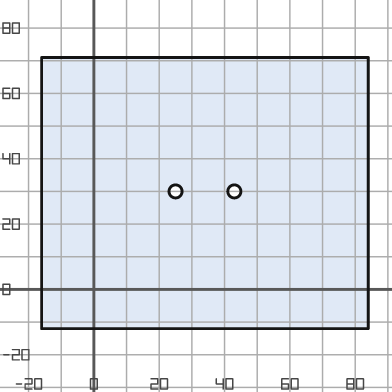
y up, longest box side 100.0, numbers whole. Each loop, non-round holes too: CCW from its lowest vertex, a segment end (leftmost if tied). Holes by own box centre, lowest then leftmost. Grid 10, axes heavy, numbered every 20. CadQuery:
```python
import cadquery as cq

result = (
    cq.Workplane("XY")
    .moveTo(-16.0, -12.0)
    .lineTo(84.0, -12.0)
    .lineTo(84.0, 71.0)
    .lineTo(-16.0, 71.0)
    .close()
    .moveTo(25.0, 30.0)
    .circle(2.0)
    .moveTo(43.0, 30.0)
    .circle(2.0)
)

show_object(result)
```